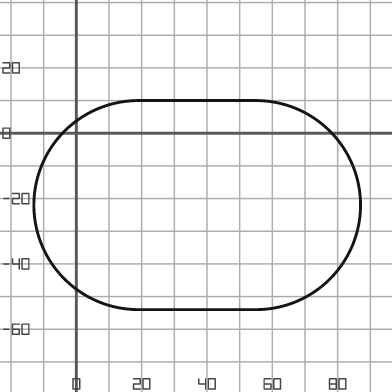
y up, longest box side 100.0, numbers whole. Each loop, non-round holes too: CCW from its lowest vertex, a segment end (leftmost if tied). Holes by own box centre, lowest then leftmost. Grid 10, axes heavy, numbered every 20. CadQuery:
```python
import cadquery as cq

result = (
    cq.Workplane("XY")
    .moveTo(19.0, -54.0)
    .lineTo(55.0, -54.0)
    .threePointArc((87.0, -22.0), (55.0, 10.0))
    .lineTo(19.0, 10.0)
    .threePointArc((-13.0, -22.0), (19.0, -54.0))
    .close()
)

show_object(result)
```